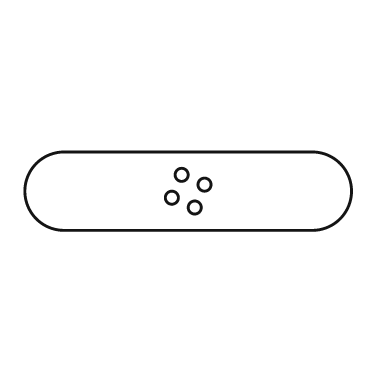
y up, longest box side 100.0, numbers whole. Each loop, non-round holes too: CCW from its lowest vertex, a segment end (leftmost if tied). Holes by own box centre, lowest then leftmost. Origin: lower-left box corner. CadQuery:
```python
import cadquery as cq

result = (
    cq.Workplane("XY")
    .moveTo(12.0, 0.0)
    .lineTo(88.0, 0.0)
    .threePointArc((100.0, 12.0), (88.0, 24.0))
    .lineTo(12.0, 24.0)
    .threePointArc((0.0, 12.0), (12.0, 0.0))
    .close()
    .moveTo(52.0, 7.0)
    .circle(2.0)
    .moveTo(45.0, 10.0)
    .circle(2.0)
    .moveTo(55.0, 14.0)
    .circle(2.0)
    .moveTo(48.0, 17.0)
    .circle(2.0)
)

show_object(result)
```